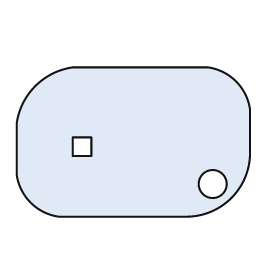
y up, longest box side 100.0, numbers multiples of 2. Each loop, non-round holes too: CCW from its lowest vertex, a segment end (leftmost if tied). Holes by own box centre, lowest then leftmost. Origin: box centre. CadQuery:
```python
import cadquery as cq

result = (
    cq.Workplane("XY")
    .moveTo(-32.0, -32.0)
    .lineTo(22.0, -32.0)
    .threePointArc((42.0, -24.0), (50.0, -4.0))
    .lineTo(50.0, 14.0)
    .threePointArc((44.0, 26.0), (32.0, 32.0))
    .lineTo(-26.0, 32.0)
    .threePointArc((-42.0, 24.0), (-50.0, 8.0))
    .lineTo(-50.0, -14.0)
    .threePointArc((-44.0, -26.0), (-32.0, -32.0))
    .close()
    .moveTo(34.0, -18.0)
    .circle(6.0)
    .moveTo(-26.0, -6.0)
    .lineTo(-18.0, -6.0)
    .lineTo(-18.0, 2.0)
    .lineTo(-26.0, 2.0)
    .close()
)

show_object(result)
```